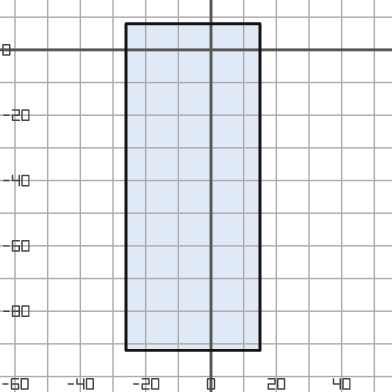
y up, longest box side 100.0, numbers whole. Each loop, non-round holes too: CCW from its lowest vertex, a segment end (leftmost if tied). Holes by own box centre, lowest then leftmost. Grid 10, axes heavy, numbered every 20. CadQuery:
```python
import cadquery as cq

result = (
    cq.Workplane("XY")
    .moveTo(-26.0, -92.0)
    .lineTo(15.0, -92.0)
    .lineTo(15.0, 8.0)
    .lineTo(-26.0, 8.0)
    .close()
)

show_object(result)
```